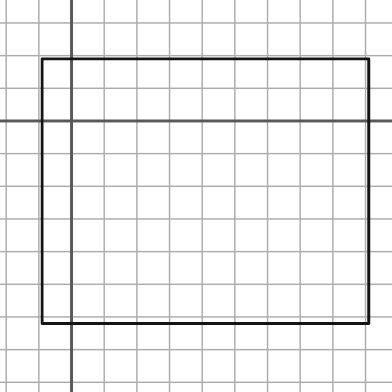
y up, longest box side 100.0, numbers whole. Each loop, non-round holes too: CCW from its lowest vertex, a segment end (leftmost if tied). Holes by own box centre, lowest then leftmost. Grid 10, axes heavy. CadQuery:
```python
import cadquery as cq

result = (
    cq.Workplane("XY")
    .moveTo(-9.0, -62.0)
    .lineTo(91.0, -62.0)
    .lineTo(91.0, 19.0)
    .lineTo(-9.0, 19.0)
    .close()
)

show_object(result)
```